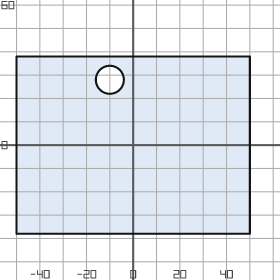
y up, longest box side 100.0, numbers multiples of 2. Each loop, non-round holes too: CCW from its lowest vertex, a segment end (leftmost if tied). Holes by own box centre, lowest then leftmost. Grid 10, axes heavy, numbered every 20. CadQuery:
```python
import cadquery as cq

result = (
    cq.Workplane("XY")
    .moveTo(-50.0, -38.0)
    .lineTo(50.0, -38.0)
    .lineTo(50.0, 38.0)
    .lineTo(-50.0, 38.0)
    .close()
    .moveTo(-10.0, 28.0)
    .circle(6.0)
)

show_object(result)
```